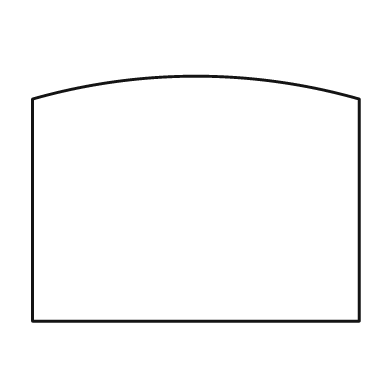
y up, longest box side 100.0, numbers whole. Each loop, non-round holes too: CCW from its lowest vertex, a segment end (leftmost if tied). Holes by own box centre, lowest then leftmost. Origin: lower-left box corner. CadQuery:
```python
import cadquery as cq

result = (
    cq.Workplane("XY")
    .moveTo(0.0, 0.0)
    .lineTo(100.0, 0.0)
    .lineTo(100.0, 68.0)
    .threePointArc((50.0, 75.0), (0.0, 68.0))
    .close()
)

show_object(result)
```